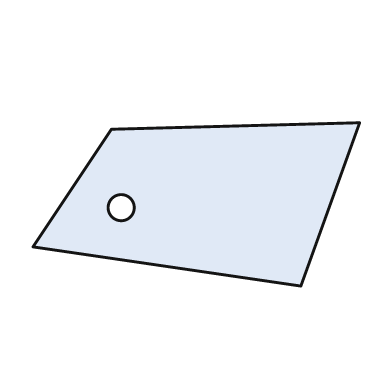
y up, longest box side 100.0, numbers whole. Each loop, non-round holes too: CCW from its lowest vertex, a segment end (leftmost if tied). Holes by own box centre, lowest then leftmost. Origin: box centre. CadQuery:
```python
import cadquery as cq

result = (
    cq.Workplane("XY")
    .moveTo(32.0, -25.0)
    .lineTo(50.0, 25.0)
    .lineTo(-26.0, 23.0)
    .lineTo(-50.0, -13.0)
    .close()
    .moveTo(-23.0, -1.0)
    .circle(4.0)
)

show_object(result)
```